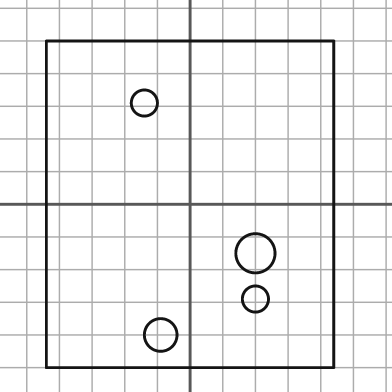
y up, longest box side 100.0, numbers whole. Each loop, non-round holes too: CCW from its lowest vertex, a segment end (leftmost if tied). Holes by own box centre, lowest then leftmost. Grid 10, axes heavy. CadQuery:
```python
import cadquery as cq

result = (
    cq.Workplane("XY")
    .moveTo(-44.0, -50.0)
    .lineTo(44.0, -50.0)
    .lineTo(44.0, 50.0)
    .lineTo(-44.0, 50.0)
    .close()
    .moveTo(-9.0, -40.0)
    .circle(5.0)
    .moveTo(20.0, -29.0)
    .circle(4.0)
    .moveTo(20.0, -15.0)
    .circle(6.0)
    .moveTo(-14.0, 31.0)
    .circle(4.0)
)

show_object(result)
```